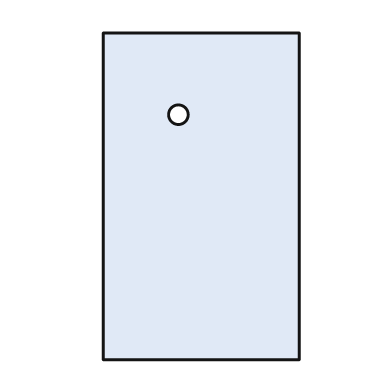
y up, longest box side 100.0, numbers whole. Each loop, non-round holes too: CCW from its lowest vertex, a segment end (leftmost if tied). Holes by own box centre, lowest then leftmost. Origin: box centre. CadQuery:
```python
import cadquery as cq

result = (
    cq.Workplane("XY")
    .moveTo(-30.0, -50.0)
    .lineTo(30.0, -50.0)
    .lineTo(30.0, 50.0)
    .lineTo(-30.0, 50.0)
    .close()
    .moveTo(-7.0, 25.0)
    .circle(3.0)
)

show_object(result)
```